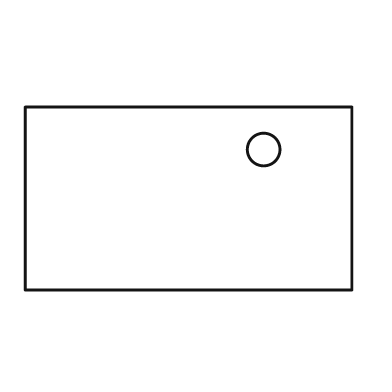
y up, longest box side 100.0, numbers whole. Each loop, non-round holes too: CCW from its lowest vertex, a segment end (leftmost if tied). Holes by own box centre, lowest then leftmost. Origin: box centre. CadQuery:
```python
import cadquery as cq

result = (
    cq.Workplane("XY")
    .moveTo(-50.0, -28.0)
    .lineTo(50.0, -28.0)
    .lineTo(50.0, 28.0)
    .lineTo(-50.0, 28.0)
    .close()
    .moveTo(23.0, 15.0)
    .circle(5.0)
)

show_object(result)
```